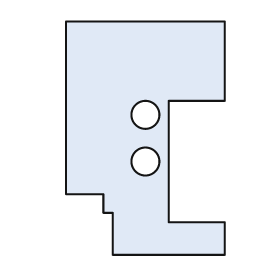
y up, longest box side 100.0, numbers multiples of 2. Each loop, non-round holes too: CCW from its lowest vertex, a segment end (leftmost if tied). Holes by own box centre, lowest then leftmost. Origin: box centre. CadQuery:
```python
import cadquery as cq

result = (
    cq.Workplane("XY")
    .moveTo(-14.0, -50.0)
    .lineTo(34.0, -50.0)
    .lineTo(34.0, -36.0)
    .lineTo(10.0, -36.0)
    .lineTo(10.0, 16.0)
    .lineTo(34.0, 16.0)
    .lineTo(34.0, 50.0)
    .lineTo(-34.0, 50.0)
    .lineTo(-34.0, -24.0)
    .lineTo(-18.0, -24.0)
    .lineTo(-18.0, -32.0)
    .lineTo(-14.0, -32.0)
    .close()
    .moveTo(0.0, -10.0)
    .circle(6.0)
    .moveTo(0.0, 10.0)
    .circle(6.0)
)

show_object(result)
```